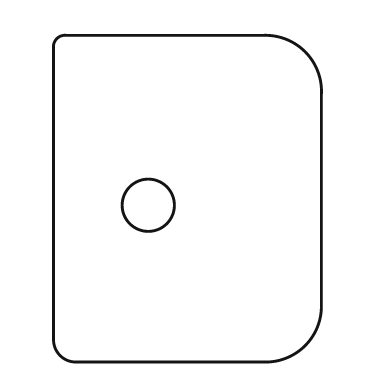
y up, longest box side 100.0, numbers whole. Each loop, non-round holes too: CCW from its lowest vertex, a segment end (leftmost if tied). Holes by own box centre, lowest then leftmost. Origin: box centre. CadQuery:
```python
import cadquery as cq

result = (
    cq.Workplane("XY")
    .moveTo(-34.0, -50.0)
    .lineTo(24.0, -50.0)
    .threePointArc((36.0, -45.0), (41.0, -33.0))
    .lineTo(41.0, 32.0)
    .threePointArc((36.0, 45.0), (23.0, 50.0))
    .lineTo(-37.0, 50.0)
    .threePointArc((-40.0, 49.0), (-41.0, 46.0))
    .lineTo(-41.0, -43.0)
    .threePointArc((-39.0, -48.0), (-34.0, -50.0))
    .close()
    .moveTo(-12.0, -2.0)
    .circle(8.0)
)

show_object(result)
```